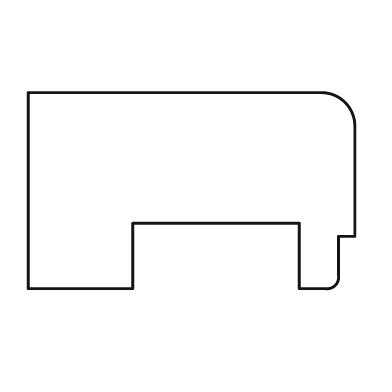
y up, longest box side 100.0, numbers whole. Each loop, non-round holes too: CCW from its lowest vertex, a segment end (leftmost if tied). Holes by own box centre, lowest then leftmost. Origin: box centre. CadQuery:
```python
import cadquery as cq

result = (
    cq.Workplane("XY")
    .moveTo(-50.0, -30.0)
    .lineTo(-18.0, -30.0)
    .lineTo(-18.0, -10.0)
    .lineTo(33.0, -10.0)
    .lineTo(33.0, -30.0)
    .lineTo(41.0, -30.0)
    .threePointArc((44.0, -29.0), (45.0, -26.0))
    .lineTo(45.0, -14.0)
    .lineTo(50.0, -14.0)
    .lineTo(50.0, 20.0)
    .threePointArc((47.0, 27.0), (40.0, 30.0))
    .lineTo(-50.0, 30.0)
    .close()
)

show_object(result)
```